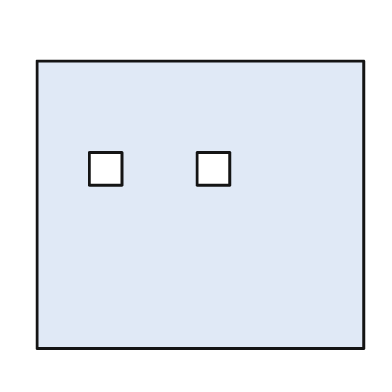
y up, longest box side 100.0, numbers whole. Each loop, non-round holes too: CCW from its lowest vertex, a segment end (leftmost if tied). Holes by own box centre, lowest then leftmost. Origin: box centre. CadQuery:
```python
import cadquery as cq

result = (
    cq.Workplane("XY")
    .moveTo(-50.0, -44.0)
    .lineTo(50.0, -44.0)
    .lineTo(50.0, 44.0)
    .lineTo(-50.0, 44.0)
    .close()
    .moveTo(-34.0, 6.0)
    .lineTo(-24.0, 6.0)
    .lineTo(-24.0, 16.0)
    .lineTo(-34.0, 16.0)
    .close()
    .moveTo(-1.0, 6.0)
    .lineTo(9.0, 6.0)
    .lineTo(9.0, 16.0)
    .lineTo(-1.0, 16.0)
    .close()
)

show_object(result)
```